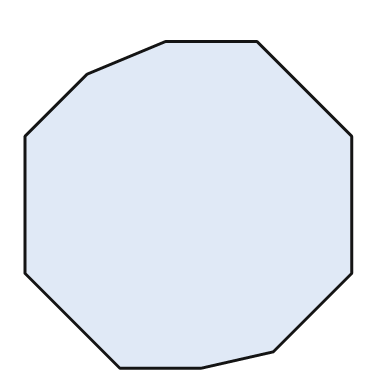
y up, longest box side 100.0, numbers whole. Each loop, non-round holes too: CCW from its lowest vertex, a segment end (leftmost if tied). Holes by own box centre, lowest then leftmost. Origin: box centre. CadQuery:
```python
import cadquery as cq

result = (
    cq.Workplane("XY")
    .moveTo(-21.0, -50.0)
    .lineTo(4.0, -50.0)
    .lineTo(26.0, -45.0)
    .lineTo(50.0, -21.0)
    .lineTo(50.0, 21.0)
    .lineTo(21.0, 50.0)
    .lineTo(-7.0, 50.0)
    .lineTo(-31.0, 40.0)
    .lineTo(-50.0, 21.0)
    .lineTo(-50.0, -21.0)
    .close()
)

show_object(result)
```